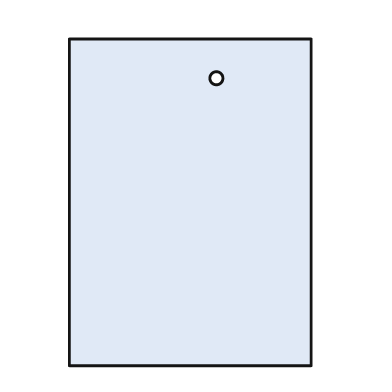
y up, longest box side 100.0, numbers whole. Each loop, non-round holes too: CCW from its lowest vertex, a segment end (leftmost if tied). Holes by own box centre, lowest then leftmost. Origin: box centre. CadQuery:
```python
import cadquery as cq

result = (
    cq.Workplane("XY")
    .moveTo(-37.0, -50.0)
    .lineTo(37.0, -50.0)
    .lineTo(37.0, 50.0)
    .lineTo(-37.0, 50.0)
    .close()
    .moveTo(8.0, 38.0)
    .circle(2.0)
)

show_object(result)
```